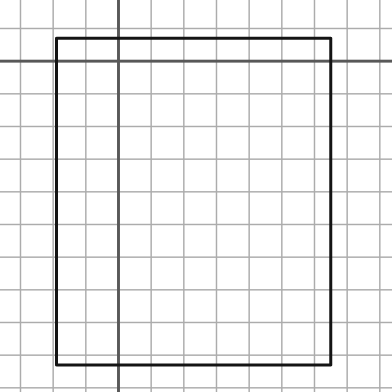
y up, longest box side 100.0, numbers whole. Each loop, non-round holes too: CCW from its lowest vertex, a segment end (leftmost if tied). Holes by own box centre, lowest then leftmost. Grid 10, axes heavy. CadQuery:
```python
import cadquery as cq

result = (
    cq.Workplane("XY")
    .moveTo(-19.0, -93.0)
    .lineTo(65.0, -93.0)
    .lineTo(65.0, 7.0)
    .lineTo(-19.0, 7.0)
    .close()
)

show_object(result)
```